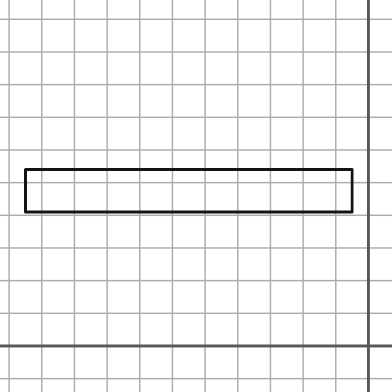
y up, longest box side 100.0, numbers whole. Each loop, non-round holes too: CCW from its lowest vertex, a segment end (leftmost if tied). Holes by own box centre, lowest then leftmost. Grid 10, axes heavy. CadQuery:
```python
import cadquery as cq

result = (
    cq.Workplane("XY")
    .moveTo(-105.0, 41.0)
    .lineTo(-5.0, 41.0)
    .lineTo(-5.0, 54.0)
    .lineTo(-105.0, 54.0)
    .close()
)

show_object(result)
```